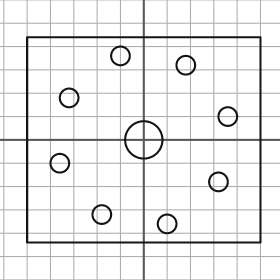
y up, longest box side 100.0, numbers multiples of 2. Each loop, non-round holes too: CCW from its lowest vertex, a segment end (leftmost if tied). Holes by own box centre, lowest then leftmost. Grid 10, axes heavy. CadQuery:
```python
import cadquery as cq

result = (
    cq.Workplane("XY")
    .moveTo(-50.0, -44.0)
    .lineTo(50.0, -44.0)
    .lineTo(50.0, 44.0)
    .lineTo(-50.0, 44.0)
    .close()
    .moveTo(10.0, -36.0)
    .circle(4.0)
    .moveTo(-18.0, -32.0)
    .circle(4.0)
    .moveTo(32.0, -18.0)
    .circle(4.0)
    .moveTo(-36.0, -10.0)
    .circle(4.0)
    .moveTo(0.0, 0.0)
    .circle(8.0)
    .moveTo(36.0, 10.0)
    .circle(4.0)
    .moveTo(-32.0, 18.0)
    .circle(4.0)
    .moveTo(18.0, 32.0)
    .circle(4.0)
    .moveTo(-10.0, 36.0)
    .circle(4.0)
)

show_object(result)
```